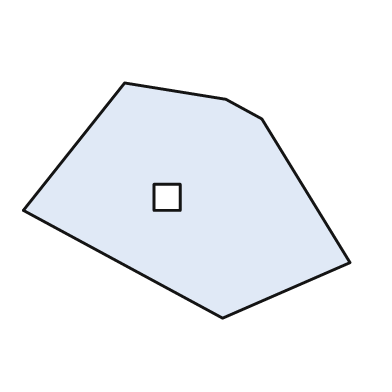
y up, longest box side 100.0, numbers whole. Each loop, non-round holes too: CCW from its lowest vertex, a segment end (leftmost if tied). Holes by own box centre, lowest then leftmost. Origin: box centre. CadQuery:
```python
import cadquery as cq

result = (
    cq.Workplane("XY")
    .moveTo(11.0, -36.0)
    .lineTo(50.0, -19.0)
    .lineTo(23.0, 25.0)
    .lineTo(12.0, 31.0)
    .lineTo(-19.0, 36.0)
    .lineTo(-50.0, -3.0)
    .close()
    .moveTo(-10.0, -3.0)
    .lineTo(-2.0, -3.0)
    .lineTo(-2.0, 5.0)
    .lineTo(-10.0, 5.0)
    .close()
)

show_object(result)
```